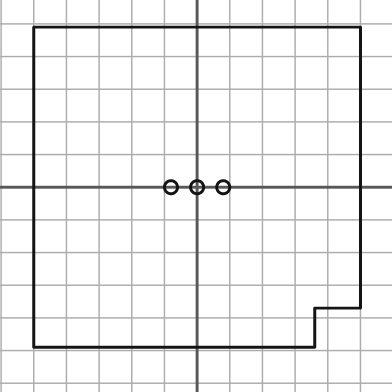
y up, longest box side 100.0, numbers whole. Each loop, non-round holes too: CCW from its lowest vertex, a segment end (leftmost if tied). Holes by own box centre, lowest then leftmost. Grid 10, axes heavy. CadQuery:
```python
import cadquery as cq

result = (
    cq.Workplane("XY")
    .moveTo(-50.0, -49.0)
    .lineTo(36.0, -49.0)
    .lineTo(36.0, -37.0)
    .lineTo(50.0, -37.0)
    .lineTo(50.0, 49.0)
    .lineTo(-50.0, 49.0)
    .close()
    .moveTo(-8.0, 0.0)
    .circle(2.0)
    .moveTo(0.0, 0.0)
    .circle(2.0)
    .moveTo(8.0, 0.0)
    .circle(2.0)
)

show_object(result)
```